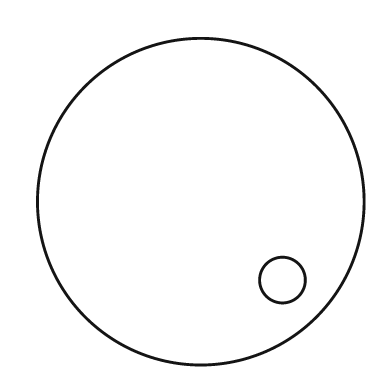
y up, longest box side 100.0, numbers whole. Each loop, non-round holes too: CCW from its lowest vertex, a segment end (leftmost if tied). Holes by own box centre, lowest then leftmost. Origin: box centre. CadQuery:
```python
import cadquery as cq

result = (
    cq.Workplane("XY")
    .moveTo(0.0, 0.0)
    .circle(50.0)
    .moveTo(25.0, -24.0)
    .circle(7.0)
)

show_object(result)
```